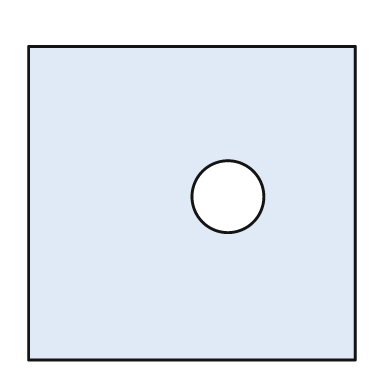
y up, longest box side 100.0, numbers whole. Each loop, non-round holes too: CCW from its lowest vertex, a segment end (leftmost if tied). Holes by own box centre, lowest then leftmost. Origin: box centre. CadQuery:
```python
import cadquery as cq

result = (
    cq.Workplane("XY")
    .moveTo(-50.0, -48.0)
    .lineTo(50.0, -48.0)
    .lineTo(50.0, 48.0)
    .lineTo(-50.0, 48.0)
    .close()
    .moveTo(11.0, 2.0)
    .circle(11.0)
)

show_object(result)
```